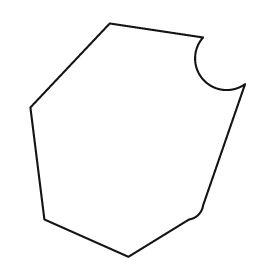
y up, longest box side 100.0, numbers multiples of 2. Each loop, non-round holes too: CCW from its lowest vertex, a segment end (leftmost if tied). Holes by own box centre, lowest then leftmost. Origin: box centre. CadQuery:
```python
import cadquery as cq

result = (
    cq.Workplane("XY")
    .moveTo(-4.0, -50.0)
    .lineTo(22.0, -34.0)
    .threePointArc((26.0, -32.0), (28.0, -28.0))
    .lineTo(46.0, 24.0)
    .threePointArc((28.0, 26.0), (28.0, 44.0))
    .lineTo(-12.0, 50.0)
    .lineTo(-46.0, 14.0)
    .lineTo(-40.0, -34.0)
    .close()
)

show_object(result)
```